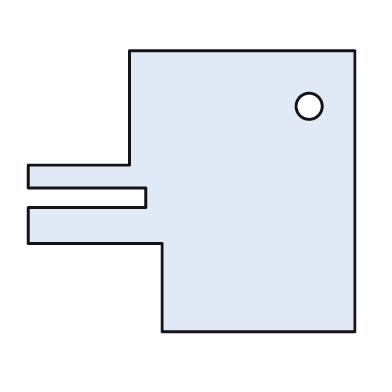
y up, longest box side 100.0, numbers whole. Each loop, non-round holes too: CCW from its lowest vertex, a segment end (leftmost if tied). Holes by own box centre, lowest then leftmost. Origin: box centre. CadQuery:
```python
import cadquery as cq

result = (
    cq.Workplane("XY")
    .moveTo(-9.0, -43.0)
    .lineTo(50.0, -43.0)
    .lineTo(50.0, 43.0)
    .lineTo(-19.0, 43.0)
    .lineTo(-19.0, 8.0)
    .lineTo(-50.0, 8.0)
    .lineTo(-50.0, 1.0)
    .lineTo(-14.0, 1.0)
    .lineTo(-14.0, -5.0)
    .lineTo(-50.0, -5.0)
    .lineTo(-50.0, -16.0)
    .lineTo(-9.0, -16.0)
    .close()
    .moveTo(36.0, 26.0)
    .circle(4.0)
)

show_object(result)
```